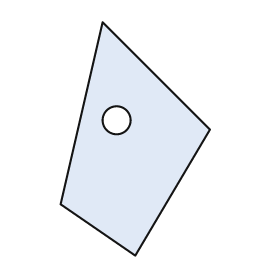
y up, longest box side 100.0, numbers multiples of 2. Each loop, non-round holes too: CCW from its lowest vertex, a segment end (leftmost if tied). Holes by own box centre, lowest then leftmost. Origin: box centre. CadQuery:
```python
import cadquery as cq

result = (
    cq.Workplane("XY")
    .moveTo(0.0, -50.0)
    .lineTo(32.0, 4.0)
    .lineTo(-14.0, 50.0)
    .lineTo(-32.0, -28.0)
    .close()
    .moveTo(-8.0, 8.0)
    .circle(6.0)
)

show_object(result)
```